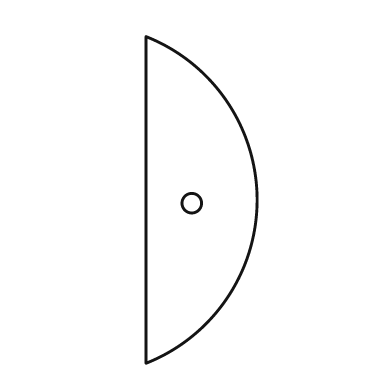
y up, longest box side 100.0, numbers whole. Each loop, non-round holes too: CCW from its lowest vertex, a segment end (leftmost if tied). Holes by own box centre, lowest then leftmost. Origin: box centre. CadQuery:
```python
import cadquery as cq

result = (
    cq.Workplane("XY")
    .moveTo(-17.0, -50.0)
    .threePointArc((17.0, 0.0), (-17.0, 50.0))
    .close()
    .moveTo(-3.0, -1.0)
    .circle(3.0)
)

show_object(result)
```